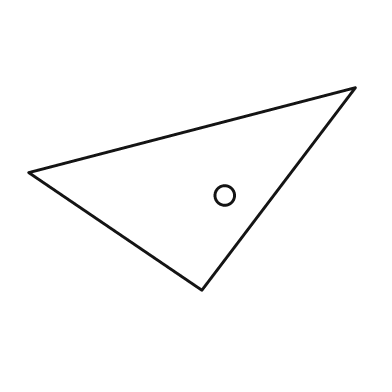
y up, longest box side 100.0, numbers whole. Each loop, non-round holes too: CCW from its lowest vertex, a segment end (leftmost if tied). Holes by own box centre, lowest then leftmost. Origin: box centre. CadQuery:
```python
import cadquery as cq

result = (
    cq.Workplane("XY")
    .moveTo(3.0, -31.0)
    .lineTo(50.0, 31.0)
    .lineTo(-50.0, 5.0)
    .close()
    .moveTo(10.0, -2.0)
    .circle(3.0)
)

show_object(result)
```